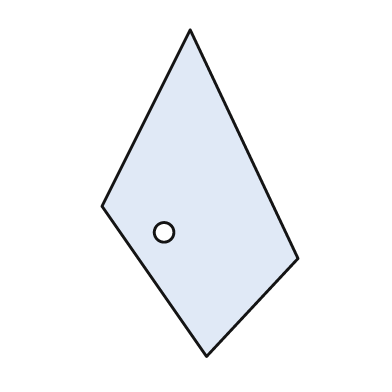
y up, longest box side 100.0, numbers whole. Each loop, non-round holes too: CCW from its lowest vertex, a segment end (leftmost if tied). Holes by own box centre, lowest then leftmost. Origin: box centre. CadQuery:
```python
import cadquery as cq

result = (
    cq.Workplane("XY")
    .moveTo(2.0, -50.0)
    .lineTo(30.0, -20.0)
    .lineTo(-3.0, 50.0)
    .lineTo(-30.0, -4.0)
    .close()
    .moveTo(-11.0, -12.0)
    .circle(3.0)
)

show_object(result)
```